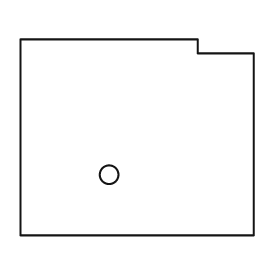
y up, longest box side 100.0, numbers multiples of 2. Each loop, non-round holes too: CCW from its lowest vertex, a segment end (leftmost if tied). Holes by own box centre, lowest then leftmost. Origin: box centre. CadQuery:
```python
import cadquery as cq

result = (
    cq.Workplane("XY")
    .moveTo(-50.0, -42.0)
    .lineTo(50.0, -42.0)
    .lineTo(50.0, 36.0)
    .lineTo(26.0, 36.0)
    .lineTo(26.0, 42.0)
    .lineTo(-50.0, 42.0)
    .close()
    .moveTo(-12.0, -16.0)
    .circle(4.0)
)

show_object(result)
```